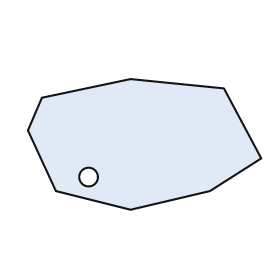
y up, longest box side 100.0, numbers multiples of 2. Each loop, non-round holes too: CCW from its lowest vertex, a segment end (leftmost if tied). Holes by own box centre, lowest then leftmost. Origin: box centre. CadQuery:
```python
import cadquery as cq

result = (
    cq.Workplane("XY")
    .moveTo(-6.0, -28.0)
    .lineTo(28.0, -20.0)
    .lineTo(50.0, -6.0)
    .lineTo(34.0, 24.0)
    .lineTo(-6.0, 28.0)
    .lineTo(-44.0, 20.0)
    .lineTo(-50.0, 6.0)
    .lineTo(-38.0, -20.0)
    .close()
    .moveTo(-24.0, -14.0)
    .circle(4.0)
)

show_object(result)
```